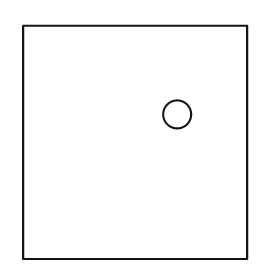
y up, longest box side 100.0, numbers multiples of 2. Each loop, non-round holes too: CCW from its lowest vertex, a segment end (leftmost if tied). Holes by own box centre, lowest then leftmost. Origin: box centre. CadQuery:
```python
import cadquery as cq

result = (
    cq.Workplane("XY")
    .moveTo(-48.0, -50.0)
    .lineTo(48.0, -50.0)
    .lineTo(48.0, 50.0)
    .lineTo(-48.0, 50.0)
    .close()
    .moveTo(18.0, 12.0)
    .circle(6.0)
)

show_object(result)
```